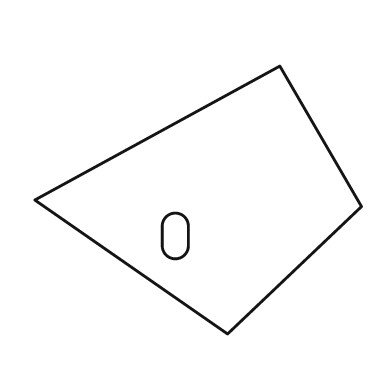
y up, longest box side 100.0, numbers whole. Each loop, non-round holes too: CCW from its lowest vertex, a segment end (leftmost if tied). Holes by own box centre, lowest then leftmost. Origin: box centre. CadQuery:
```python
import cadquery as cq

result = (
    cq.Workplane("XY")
    .moveTo(9.0, -41.0)
    .lineTo(50.0, -2.0)
    .lineTo(25.0, 41.0)
    .lineTo(-50.0, 0.0)
    .close()
    .moveTo(-11.0, -14.0)
    .threePointArc((-7.0, -18.0), (-3.0, -14.0))
    .lineTo(-3.0, -8.0)
    .threePointArc((-7.0, -4.0), (-11.0, -8.0))
    .close()
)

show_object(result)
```